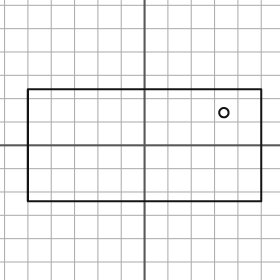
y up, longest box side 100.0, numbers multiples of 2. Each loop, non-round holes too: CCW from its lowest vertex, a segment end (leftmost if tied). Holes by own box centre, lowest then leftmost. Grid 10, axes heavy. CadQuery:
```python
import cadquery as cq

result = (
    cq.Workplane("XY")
    .moveTo(-50.0, -24.0)
    .lineTo(50.0, -24.0)
    .lineTo(50.0, 24.0)
    .lineTo(-50.0, 24.0)
    .close()
    .moveTo(34.0, 14.0)
    .circle(2.0)
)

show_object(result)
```